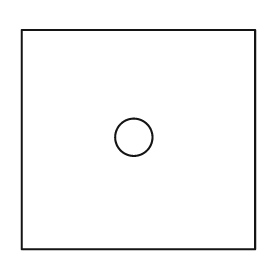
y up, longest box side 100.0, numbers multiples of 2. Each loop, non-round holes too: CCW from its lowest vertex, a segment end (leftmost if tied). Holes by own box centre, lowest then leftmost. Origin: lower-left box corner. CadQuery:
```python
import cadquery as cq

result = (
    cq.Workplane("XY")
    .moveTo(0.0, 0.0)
    .lineTo(100.0, 0.0)
    .lineTo(100.0, 94.0)
    .lineTo(0.0, 94.0)
    .close()
    .moveTo(48.0, 48.0)
    .circle(8.0)
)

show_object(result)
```